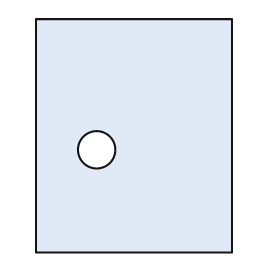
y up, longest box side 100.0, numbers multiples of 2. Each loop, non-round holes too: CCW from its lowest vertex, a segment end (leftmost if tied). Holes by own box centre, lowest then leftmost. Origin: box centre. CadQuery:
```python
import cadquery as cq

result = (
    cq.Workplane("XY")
    .moveTo(-42.0, -50.0)
    .lineTo(42.0, -50.0)
    .lineTo(42.0, 50.0)
    .lineTo(-42.0, 50.0)
    .close()
    .moveTo(-16.0, -6.0)
    .circle(8.0)
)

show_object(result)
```